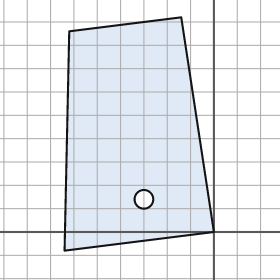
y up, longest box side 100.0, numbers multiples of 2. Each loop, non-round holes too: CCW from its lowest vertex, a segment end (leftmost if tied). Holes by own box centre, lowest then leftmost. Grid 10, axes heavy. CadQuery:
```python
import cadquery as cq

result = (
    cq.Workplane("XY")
    .moveTo(-64.0, -8.0)
    .lineTo(0.0, 0.0)
    .lineTo(-14.0, 92.0)
    .lineTo(-62.0, 86.0)
    .close()
    .moveTo(-30.0, 14.0)
    .circle(4.0)
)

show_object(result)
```